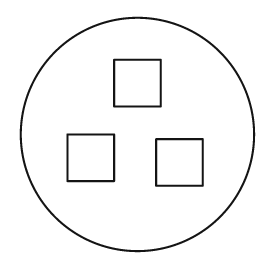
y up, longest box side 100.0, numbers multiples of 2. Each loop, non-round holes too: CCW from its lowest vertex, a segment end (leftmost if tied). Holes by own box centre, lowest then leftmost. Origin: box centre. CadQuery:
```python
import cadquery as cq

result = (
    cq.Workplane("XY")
    .moveTo(0.0, 0.0)
    .circle(50.0)
    .moveTo(8.0, -22.0)
    .lineTo(28.0, -22.0)
    .lineTo(28.0, -2.0)
    .lineTo(8.0, -2.0)
    .close()
    .moveTo(-30.0, -20.0)
    .lineTo(-10.0, -20.0)
    .lineTo(-10.0, 0.0)
    .lineTo(-30.0, 0.0)
    .close()
    .moveTo(-10.0, 12.0)
    .lineTo(10.0, 12.0)
    .lineTo(10.0, 32.0)
    .lineTo(-10.0, 32.0)
    .close()
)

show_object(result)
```